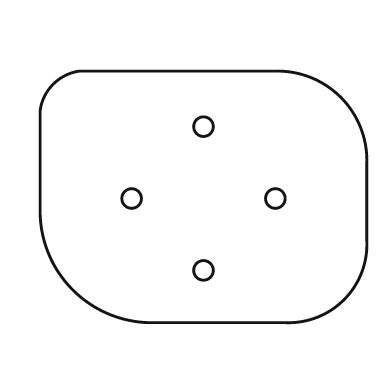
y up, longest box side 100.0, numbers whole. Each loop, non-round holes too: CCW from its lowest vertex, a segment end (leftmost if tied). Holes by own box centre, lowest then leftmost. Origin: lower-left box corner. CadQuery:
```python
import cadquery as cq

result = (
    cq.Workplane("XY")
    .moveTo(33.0, 0.0)
    .lineTo(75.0, 0.0)
    .threePointArc((93.0, 7.0), (100.0, 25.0))
    .lineTo(100.0, 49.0)
    .threePointArc((92.0, 69.0), (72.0, 77.0))
    .lineTo(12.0, 77.0)
    .threePointArc((4.0, 73.0), (0.0, 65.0))
    .lineTo(0.0, 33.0)
    .threePointArc((10.0, 10.0), (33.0, 0.0))
    .close()
    .moveTo(50.0, 16.0)
    .circle(3.0)
    .moveTo(28.0, 38.0)
    .circle(3.0)
    .moveTo(72.0, 38.0)
    .circle(3.0)
    .moveTo(50.0, 60.0)
    .circle(3.0)
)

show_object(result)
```